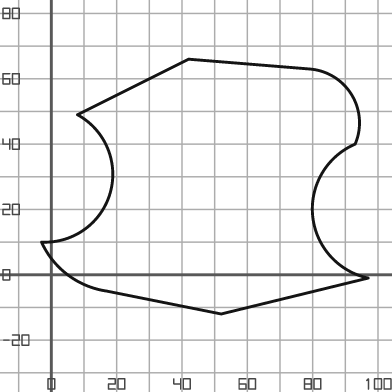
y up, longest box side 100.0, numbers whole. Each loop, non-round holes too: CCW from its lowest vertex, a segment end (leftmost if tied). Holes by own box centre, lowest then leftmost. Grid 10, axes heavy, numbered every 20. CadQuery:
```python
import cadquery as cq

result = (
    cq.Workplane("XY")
    .moveTo(52.0, -12.0)
    .lineTo(97.0, -1.0)
    .threePointArc((80.0, 18.0), (93.0, 40.0))
    .threePointArc((92.0, 55.0), (79.0, 63.0))
    .lineTo(42.0, 66.0)
    .lineTo(8.0, 49.0)
    .threePointArc((18.0, 25.0), (-3.0, 10.0))
    .threePointArc((5.0, 0.0), (17.0, -5.0))
    .close()
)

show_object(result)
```